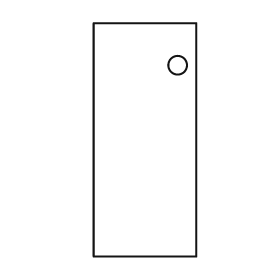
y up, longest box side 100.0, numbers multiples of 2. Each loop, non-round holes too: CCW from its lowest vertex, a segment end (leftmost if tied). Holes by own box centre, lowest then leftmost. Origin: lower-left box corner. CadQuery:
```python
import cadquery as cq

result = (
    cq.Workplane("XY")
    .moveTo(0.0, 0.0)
    .lineTo(44.0, 0.0)
    .lineTo(44.0, 100.0)
    .lineTo(0.0, 100.0)
    .close()
    .moveTo(36.0, 82.0)
    .circle(4.0)
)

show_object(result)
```